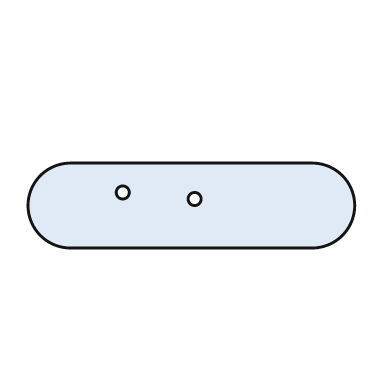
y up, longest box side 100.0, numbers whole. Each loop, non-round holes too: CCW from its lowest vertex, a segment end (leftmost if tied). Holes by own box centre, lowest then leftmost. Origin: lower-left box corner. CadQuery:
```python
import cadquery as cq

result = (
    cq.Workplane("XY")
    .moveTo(13.0, 0.0)
    .lineTo(87.0, 0.0)
    .threePointArc((100.0, 13.0), (87.0, 26.0))
    .lineTo(13.0, 26.0)
    .threePointArc((0.0, 13.0), (13.0, 0.0))
    .close()
    .moveTo(51.0, 15.0)
    .circle(2.0)
    .moveTo(29.0, 17.0)
    .circle(2.0)
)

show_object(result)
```